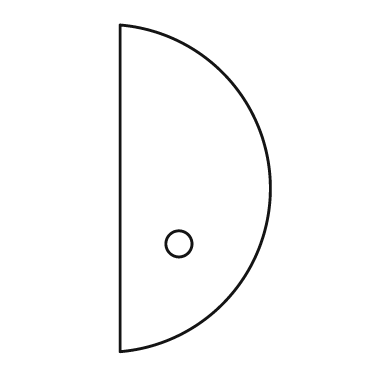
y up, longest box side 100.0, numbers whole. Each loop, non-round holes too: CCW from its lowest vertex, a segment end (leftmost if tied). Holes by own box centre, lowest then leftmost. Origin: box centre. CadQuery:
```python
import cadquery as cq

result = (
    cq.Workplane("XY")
    .moveTo(-23.0, -50.0)
    .threePointArc((23.0, 0.0), (-23.0, 50.0))
    .close()
    .moveTo(-5.0, -17.0)
    .circle(4.0)
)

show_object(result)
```